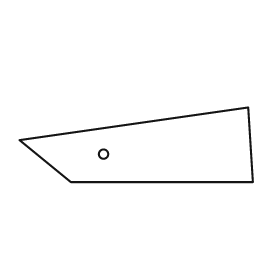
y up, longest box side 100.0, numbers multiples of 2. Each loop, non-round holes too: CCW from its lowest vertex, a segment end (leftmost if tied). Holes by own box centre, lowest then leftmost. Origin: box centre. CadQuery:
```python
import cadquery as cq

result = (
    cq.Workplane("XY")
    .moveTo(-28.0, -16.0)
    .lineTo(50.0, -16.0)
    .lineTo(48.0, 16.0)
    .lineTo(-50.0, 2.0)
    .close()
    .moveTo(-14.0, -4.0)
    .circle(2.0)
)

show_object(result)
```